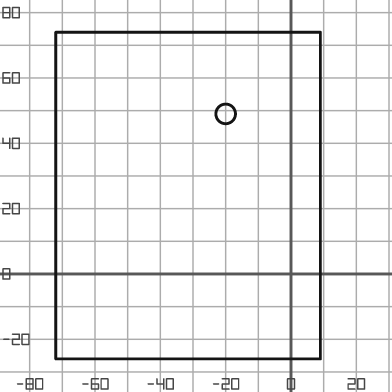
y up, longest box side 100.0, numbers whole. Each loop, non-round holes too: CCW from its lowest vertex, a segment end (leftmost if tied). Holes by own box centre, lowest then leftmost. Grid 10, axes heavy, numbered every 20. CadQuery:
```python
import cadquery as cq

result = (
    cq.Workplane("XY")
    .moveTo(-72.0, -26.0)
    .lineTo(9.0, -26.0)
    .lineTo(9.0, 74.0)
    .lineTo(-72.0, 74.0)
    .close()
    .moveTo(-20.0, 49.0)
    .circle(3.0)
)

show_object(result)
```